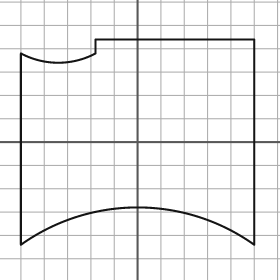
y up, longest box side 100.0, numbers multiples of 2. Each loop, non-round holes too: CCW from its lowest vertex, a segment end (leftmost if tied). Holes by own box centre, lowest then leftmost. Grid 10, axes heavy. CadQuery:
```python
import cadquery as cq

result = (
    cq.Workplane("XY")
    .moveTo(-50.0, -44.0)
    .threePointArc((0.0, -28.0), (50.0, -44.0))
    .lineTo(50.0, 44.0)
    .lineTo(-18.0, 44.0)
    .lineTo(-18.0, 38.0)
    .threePointArc((-34.0, 34.0), (-50.0, 38.0))
    .close()
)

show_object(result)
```